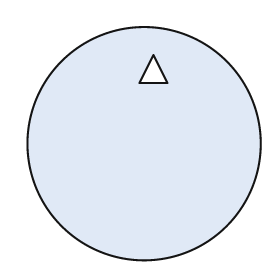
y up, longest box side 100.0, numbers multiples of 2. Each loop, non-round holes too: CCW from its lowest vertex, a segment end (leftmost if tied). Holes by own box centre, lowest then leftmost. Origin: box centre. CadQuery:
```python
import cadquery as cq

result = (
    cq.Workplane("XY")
    .moveTo(0.0, 0.0)
    .circle(50.0)
    .moveTo(-2.0, 26.0)
    .lineTo(10.0, 26.0)
    .lineTo(4.0, 38.0)
    .close()
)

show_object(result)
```